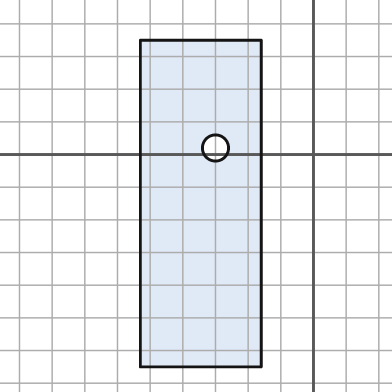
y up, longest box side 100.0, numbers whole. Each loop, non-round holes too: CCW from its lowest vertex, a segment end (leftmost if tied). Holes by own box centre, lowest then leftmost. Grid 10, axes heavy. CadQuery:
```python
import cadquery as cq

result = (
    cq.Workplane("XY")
    .moveTo(-53.0, -65.0)
    .lineTo(-16.0, -65.0)
    .lineTo(-16.0, 35.0)
    .lineTo(-53.0, 35.0)
    .close()
    .moveTo(-30.0, 2.0)
    .circle(4.0)
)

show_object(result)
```